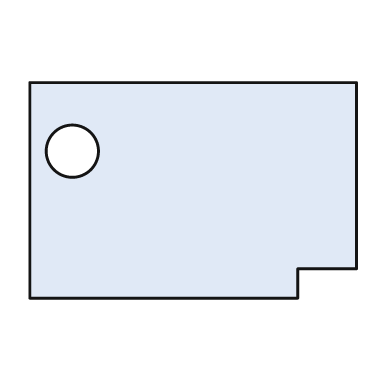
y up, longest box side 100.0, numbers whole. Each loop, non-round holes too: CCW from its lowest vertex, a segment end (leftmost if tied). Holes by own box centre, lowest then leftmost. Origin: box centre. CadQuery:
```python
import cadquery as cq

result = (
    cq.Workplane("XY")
    .moveTo(-50.0, -33.0)
    .lineTo(32.0, -33.0)
    .lineTo(32.0, -24.0)
    .lineTo(50.0, -24.0)
    .lineTo(50.0, 33.0)
    .lineTo(-50.0, 33.0)
    .close()
    .moveTo(-37.0, 12.0)
    .circle(8.0)
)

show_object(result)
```